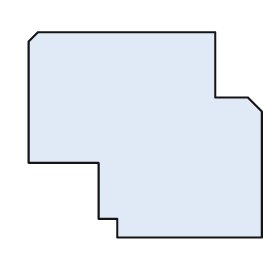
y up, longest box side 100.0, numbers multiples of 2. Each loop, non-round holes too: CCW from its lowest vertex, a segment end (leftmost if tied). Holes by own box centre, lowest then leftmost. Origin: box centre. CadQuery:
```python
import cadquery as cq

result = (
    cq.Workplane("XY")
    .moveTo(-12.0, -44.0)
    .lineTo(50.0, -44.0)
    .lineTo(50.0, 10.0)
    .lineTo(44.0, 16.0)
    .lineTo(30.0, 16.0)
    .lineTo(30.0, 44.0)
    .lineTo(-46.0, 44.0)
    .lineTo(-50.0, 40.0)
    .lineTo(-50.0, -12.0)
    .lineTo(-20.0, -12.0)
    .lineTo(-20.0, -36.0)
    .lineTo(-12.0, -36.0)
    .close()
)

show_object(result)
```